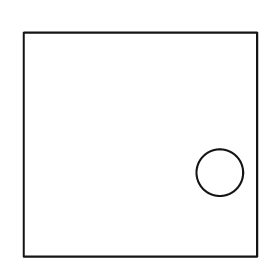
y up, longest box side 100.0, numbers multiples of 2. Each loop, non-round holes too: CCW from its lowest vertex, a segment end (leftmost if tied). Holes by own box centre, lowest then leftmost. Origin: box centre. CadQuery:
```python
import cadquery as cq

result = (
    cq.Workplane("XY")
    .moveTo(-50.0, -48.0)
    .lineTo(50.0, -48.0)
    .lineTo(50.0, 48.0)
    .lineTo(-50.0, 48.0)
    .close()
    .moveTo(34.0, -12.0)
    .circle(10.0)
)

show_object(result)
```